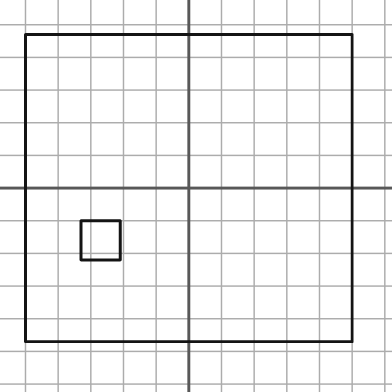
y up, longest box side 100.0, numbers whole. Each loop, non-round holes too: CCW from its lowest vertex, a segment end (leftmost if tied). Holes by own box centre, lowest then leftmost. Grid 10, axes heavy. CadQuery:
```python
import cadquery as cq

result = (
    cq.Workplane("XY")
    .moveTo(-50.0, -47.0)
    .lineTo(50.0, -47.0)
    .lineTo(50.0, 47.0)
    .lineTo(-50.0, 47.0)
    .close()
    .moveTo(-33.0, -22.0)
    .lineTo(-21.0, -22.0)
    .lineTo(-21.0, -10.0)
    .lineTo(-33.0, -10.0)
    .close()
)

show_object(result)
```